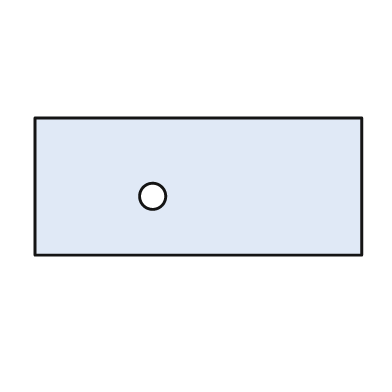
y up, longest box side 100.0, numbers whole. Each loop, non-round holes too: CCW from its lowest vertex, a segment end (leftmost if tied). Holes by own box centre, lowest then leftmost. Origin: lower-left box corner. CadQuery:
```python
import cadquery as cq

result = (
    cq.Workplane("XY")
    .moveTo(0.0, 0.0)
    .lineTo(100.0, 0.0)
    .lineTo(100.0, 42.0)
    .lineTo(0.0, 42.0)
    .close()
    .moveTo(36.0, 18.0)
    .circle(4.0)
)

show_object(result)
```